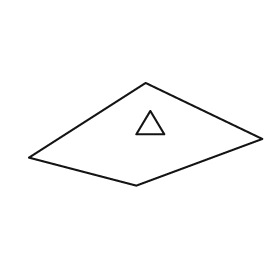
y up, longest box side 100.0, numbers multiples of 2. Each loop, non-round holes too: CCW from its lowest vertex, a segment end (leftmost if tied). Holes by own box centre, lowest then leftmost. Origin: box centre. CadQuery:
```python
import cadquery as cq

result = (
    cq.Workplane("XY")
    .moveTo(-4.0, -22.0)
    .lineTo(50.0, -2.0)
    .lineTo(0.0, 22.0)
    .lineTo(-50.0, -10.0)
    .close()
    .moveTo(-4.0, 0.0)
    .lineTo(8.0, 0.0)
    .lineTo(2.0, 10.0)
    .close()
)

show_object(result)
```